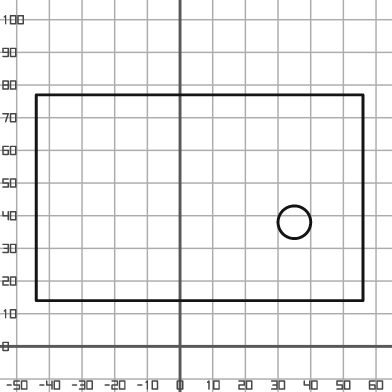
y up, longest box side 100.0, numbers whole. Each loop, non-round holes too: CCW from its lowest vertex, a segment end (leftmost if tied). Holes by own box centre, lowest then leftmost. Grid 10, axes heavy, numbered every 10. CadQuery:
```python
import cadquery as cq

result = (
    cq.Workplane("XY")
    .moveTo(-44.0, 14.0)
    .lineTo(56.0, 14.0)
    .lineTo(56.0, 77.0)
    .lineTo(-44.0, 77.0)
    .close()
    .moveTo(35.0, 38.0)
    .circle(5.0)
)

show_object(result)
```